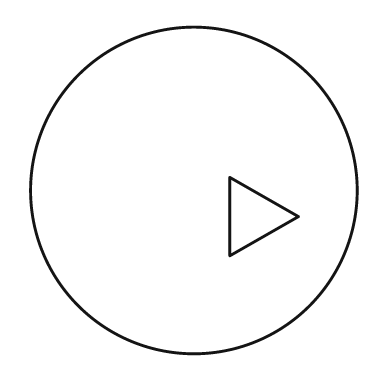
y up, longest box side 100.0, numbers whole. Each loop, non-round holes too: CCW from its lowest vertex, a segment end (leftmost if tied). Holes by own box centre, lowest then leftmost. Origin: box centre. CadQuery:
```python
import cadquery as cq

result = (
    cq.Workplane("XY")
    .moveTo(0.0, 0.0)
    .circle(50.0)
    .moveTo(11.0, -20.0)
    .lineTo(32.0, -8.0)
    .lineTo(11.0, 4.0)
    .close()
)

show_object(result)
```